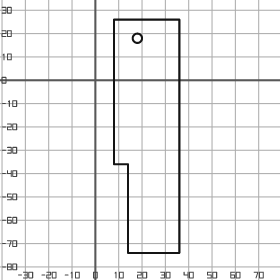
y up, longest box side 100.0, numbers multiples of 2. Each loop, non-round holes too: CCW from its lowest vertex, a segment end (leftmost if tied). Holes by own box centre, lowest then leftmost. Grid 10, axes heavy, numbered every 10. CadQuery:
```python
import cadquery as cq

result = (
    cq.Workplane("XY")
    .moveTo(14.0, -74.0)
    .lineTo(36.0, -74.0)
    .lineTo(36.0, 26.0)
    .lineTo(8.0, 26.0)
    .lineTo(8.0, -36.0)
    .lineTo(14.0, -36.0)
    .close()
    .moveTo(18.0, 18.0)
    .circle(2.0)
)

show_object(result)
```